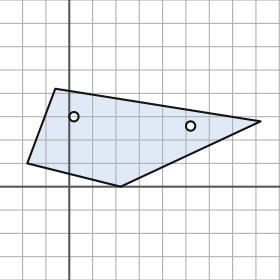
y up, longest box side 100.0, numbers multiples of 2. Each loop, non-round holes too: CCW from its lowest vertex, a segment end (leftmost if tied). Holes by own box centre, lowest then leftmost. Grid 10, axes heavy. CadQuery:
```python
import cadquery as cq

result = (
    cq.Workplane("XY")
    .moveTo(22.0, 0.0)
    .lineTo(82.0, 28.0)
    .lineTo(-6.0, 42.0)
    .lineTo(-18.0, 10.0)
    .close()
    .moveTo(52.0, 26.0)
    .circle(2.0)
    .moveTo(2.0, 30.0)
    .circle(2.0)
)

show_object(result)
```